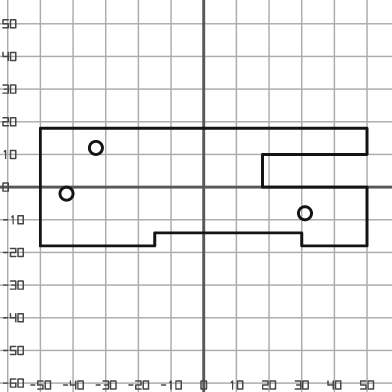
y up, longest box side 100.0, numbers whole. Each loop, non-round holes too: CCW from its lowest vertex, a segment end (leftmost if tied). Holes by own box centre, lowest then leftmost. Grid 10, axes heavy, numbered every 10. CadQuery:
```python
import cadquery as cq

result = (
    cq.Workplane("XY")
    .moveTo(-50.0, -18.0)
    .lineTo(-15.0, -18.0)
    .lineTo(-15.0, -14.0)
    .lineTo(30.0, -14.0)
    .lineTo(30.0, -18.0)
    .lineTo(50.0, -18.0)
    .lineTo(50.0, 0.0)
    .lineTo(18.0, 0.0)
    .lineTo(18.0, 10.0)
    .lineTo(50.0, 10.0)
    .lineTo(50.0, 18.0)
    .lineTo(-50.0, 18.0)
    .close()
    .moveTo(31.0, -8.0)
    .circle(2.0)
    .moveTo(-42.0, -2.0)
    .circle(2.0)
    .moveTo(-33.0, 12.0)
    .circle(2.0)
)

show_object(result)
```